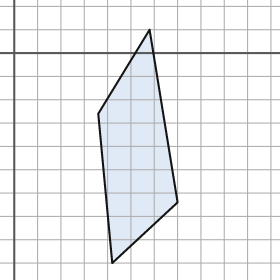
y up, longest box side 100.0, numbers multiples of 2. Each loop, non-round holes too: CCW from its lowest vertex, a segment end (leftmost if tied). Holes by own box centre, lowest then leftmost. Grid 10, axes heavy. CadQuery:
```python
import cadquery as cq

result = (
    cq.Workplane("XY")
    .moveTo(42.0, -90.0)
    .lineTo(70.0, -64.0)
    .lineTo(58.0, 10.0)
    .lineTo(36.0, -26.0)
    .close()
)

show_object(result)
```